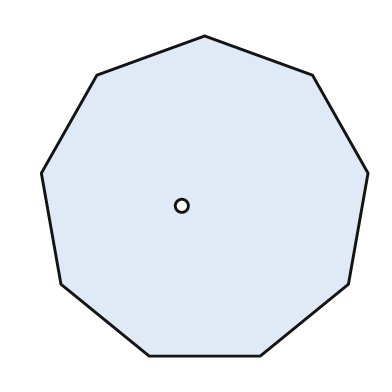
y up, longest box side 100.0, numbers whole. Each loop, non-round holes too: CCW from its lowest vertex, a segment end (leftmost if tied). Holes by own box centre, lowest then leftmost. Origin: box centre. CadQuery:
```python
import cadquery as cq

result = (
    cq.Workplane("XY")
    .moveTo(-17.0, -49.0)
    .lineTo(17.0, -49.0)
    .lineTo(44.0, -27.0)
    .lineTo(50.0, 7.0)
    .lineTo(33.0, 37.0)
    .lineTo(0.0, 49.0)
    .lineTo(-33.0, 37.0)
    .lineTo(-50.0, 7.0)
    .lineTo(-44.0, -27.0)
    .close()
    .moveTo(-7.0, -3.0)
    .circle(2.0)
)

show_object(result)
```